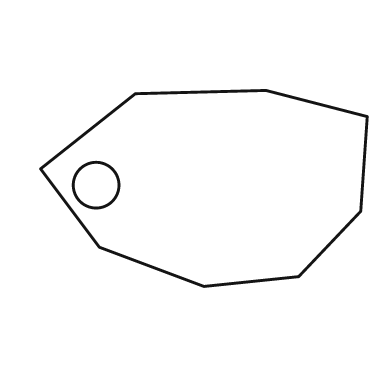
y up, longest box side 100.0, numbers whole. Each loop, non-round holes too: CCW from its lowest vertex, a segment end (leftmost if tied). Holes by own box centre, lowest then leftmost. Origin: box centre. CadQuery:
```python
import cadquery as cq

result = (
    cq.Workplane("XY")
    .moveTo(0.0, -30.0)
    .lineTo(29.0, -27.0)
    .lineTo(48.0, -7.0)
    .lineTo(50.0, 22.0)
    .lineTo(19.0, 30.0)
    .lineTo(-21.0, 29.0)
    .lineTo(-50.0, 6.0)
    .lineTo(-32.0, -18.0)
    .close()
    .moveTo(-33.0, 1.0)
    .circle(7.0)
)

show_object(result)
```